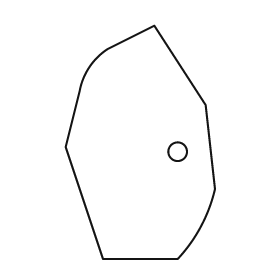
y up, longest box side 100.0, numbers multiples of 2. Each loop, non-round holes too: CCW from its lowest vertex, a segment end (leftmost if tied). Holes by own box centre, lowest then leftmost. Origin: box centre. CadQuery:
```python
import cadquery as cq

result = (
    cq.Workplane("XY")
    .moveTo(-16.0, -50.0)
    .lineTo(16.0, -50.0)
    .threePointArc((26.0, -36.0), (32.0, -20.0))
    .lineTo(28.0, 16.0)
    .lineTo(6.0, 50.0)
    .lineTo(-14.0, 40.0)
    .threePointArc((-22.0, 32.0), (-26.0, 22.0))
    .lineTo(-32.0, -2.0)
    .close()
    .moveTo(16.0, -4.0)
    .circle(4.0)
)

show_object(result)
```